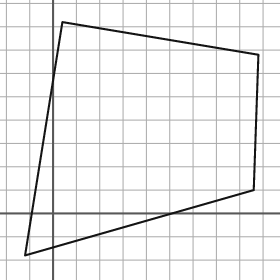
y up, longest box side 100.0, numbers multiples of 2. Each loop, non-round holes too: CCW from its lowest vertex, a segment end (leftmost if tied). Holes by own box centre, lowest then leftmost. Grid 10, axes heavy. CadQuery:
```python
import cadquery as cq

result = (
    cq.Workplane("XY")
    .moveTo(-12.0, -18.0)
    .lineTo(86.0, 10.0)
    .lineTo(88.0, 68.0)
    .lineTo(4.0, 82.0)
    .close()
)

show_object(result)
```